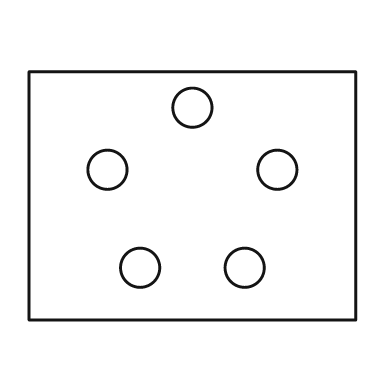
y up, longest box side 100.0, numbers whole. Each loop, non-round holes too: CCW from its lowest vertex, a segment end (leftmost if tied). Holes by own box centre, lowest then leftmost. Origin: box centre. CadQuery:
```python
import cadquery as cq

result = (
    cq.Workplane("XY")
    .moveTo(-50.0, -38.0)
    .lineTo(50.0, -38.0)
    .lineTo(50.0, 38.0)
    .lineTo(-50.0, 38.0)
    .close()
    .moveTo(-16.0, -22.0)
    .circle(6.0)
    .moveTo(16.0, -22.0)
    .circle(6.0)
    .moveTo(-26.0, 8.0)
    .circle(6.0)
    .moveTo(26.0, 8.0)
    .circle(6.0)
    .moveTo(0.0, 27.0)
    .circle(6.0)
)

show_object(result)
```